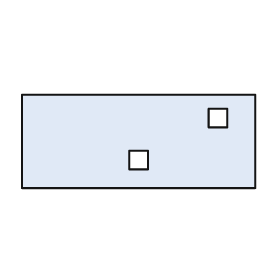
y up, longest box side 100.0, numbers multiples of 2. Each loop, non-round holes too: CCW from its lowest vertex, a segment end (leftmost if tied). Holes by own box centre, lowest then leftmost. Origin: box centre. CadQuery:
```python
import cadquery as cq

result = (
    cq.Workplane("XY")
    .moveTo(-50.0, -20.0)
    .lineTo(50.0, -20.0)
    .lineTo(50.0, 20.0)
    .lineTo(-50.0, 20.0)
    .close()
    .moveTo(-4.0, -12.0)
    .lineTo(4.0, -12.0)
    .lineTo(4.0, -4.0)
    .lineTo(-4.0, -4.0)
    .close()
    .moveTo(30.0, 6.0)
    .lineTo(38.0, 6.0)
    .lineTo(38.0, 14.0)
    .lineTo(30.0, 14.0)
    .close()
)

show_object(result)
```